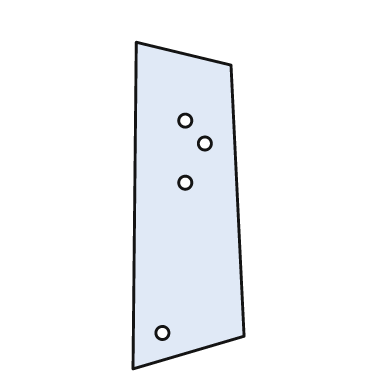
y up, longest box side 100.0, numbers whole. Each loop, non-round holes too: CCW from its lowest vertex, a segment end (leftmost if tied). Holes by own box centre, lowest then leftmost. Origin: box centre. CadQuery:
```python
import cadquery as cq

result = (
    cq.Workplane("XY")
    .moveTo(-17.0, -50.0)
    .lineTo(17.0, -40.0)
    .lineTo(13.0, 43.0)
    .lineTo(-16.0, 50.0)
    .close()
    .moveTo(-8.0, -39.0)
    .circle(2.0)
    .moveTo(-1.0, 7.0)
    .circle(2.0)
    .moveTo(5.0, 19.0)
    .circle(2.0)
    .moveTo(-1.0, 26.0)
    .circle(2.0)
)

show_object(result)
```